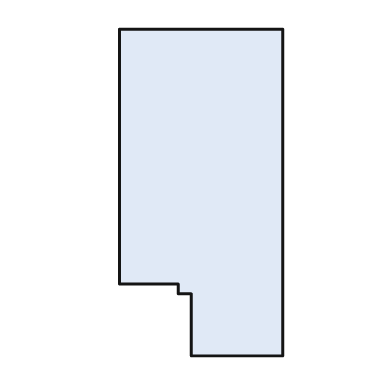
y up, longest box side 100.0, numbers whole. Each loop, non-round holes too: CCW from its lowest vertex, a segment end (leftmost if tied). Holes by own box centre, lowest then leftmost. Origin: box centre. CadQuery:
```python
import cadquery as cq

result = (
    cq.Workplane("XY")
    .moveTo(-3.0, -50.0)
    .lineTo(25.0, -50.0)
    .lineTo(25.0, 50.0)
    .lineTo(-25.0, 50.0)
    .lineTo(-25.0, -28.0)
    .lineTo(-7.0, -28.0)
    .lineTo(-7.0, -31.0)
    .lineTo(-3.0, -31.0)
    .close()
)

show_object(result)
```